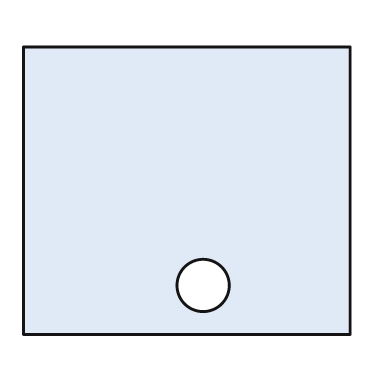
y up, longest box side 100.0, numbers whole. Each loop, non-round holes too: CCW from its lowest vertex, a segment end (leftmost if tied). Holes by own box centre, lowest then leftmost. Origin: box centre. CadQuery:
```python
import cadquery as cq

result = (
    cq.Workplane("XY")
    .moveTo(-50.0, -44.0)
    .lineTo(50.0, -44.0)
    .lineTo(50.0, 44.0)
    .lineTo(-50.0, 44.0)
    .close()
    .moveTo(5.0, -29.0)
    .circle(8.0)
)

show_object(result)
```